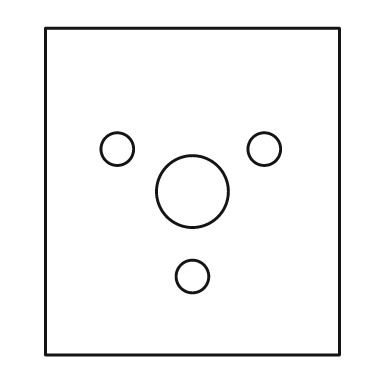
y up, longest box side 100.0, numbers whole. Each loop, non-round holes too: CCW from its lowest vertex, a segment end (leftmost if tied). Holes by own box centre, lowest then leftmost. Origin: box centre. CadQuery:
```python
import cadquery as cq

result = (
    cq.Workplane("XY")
    .moveTo(-45.0, -50.0)
    .lineTo(45.0, -50.0)
    .lineTo(45.0, 50.0)
    .lineTo(-45.0, 50.0)
    .close()
    .moveTo(0.0, -26.0)
    .circle(5.0)
    .moveTo(0.0, 0.0)
    .circle(11.0)
    .moveTo(-23.0, 13.0)
    .circle(5.0)
    .moveTo(22.0, 13.0)
    .circle(5.0)
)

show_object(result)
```